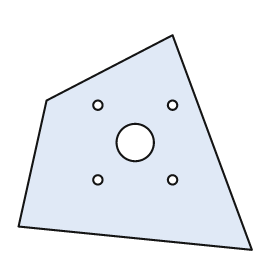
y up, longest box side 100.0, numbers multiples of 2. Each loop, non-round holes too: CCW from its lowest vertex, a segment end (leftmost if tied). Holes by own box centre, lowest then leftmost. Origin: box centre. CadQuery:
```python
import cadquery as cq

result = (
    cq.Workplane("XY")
    .moveTo(50.0, -46.0)
    .lineTo(16.0, 46.0)
    .lineTo(-38.0, 18.0)
    .lineTo(-50.0, -36.0)
    .close()
    .moveTo(-16.0, -16.0)
    .circle(2.0)
    .moveTo(16.0, -16.0)
    .circle(2.0)
    .moveTo(0.0, 0.0)
    .circle(8.0)
    .moveTo(-16.0, 16.0)
    .circle(2.0)
    .moveTo(16.0, 16.0)
    .circle(2.0)
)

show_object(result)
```